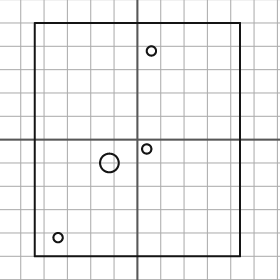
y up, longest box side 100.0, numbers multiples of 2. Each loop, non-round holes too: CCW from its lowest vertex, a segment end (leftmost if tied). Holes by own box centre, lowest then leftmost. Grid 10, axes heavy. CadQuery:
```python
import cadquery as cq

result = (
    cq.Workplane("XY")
    .moveTo(-44.0, -50.0)
    .lineTo(44.0, -50.0)
    .lineTo(44.0, 50.0)
    .lineTo(-44.0, 50.0)
    .close()
    .moveTo(-34.0, -42.0)
    .circle(2.0)
    .moveTo(-12.0, -10.0)
    .circle(4.0)
    .moveTo(4.0, -4.0)
    .circle(2.0)
    .moveTo(6.0, 38.0)
    .circle(2.0)
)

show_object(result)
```